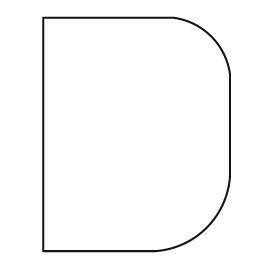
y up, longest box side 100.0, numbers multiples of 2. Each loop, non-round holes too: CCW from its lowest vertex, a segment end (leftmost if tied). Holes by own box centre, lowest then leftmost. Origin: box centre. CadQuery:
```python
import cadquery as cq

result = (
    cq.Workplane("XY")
    .moveTo(-40.0, -50.0)
    .lineTo(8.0, -50.0)
    .threePointArc((30.0, -40.0), (40.0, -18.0))
    .lineTo(40.0, 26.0)
    .threePointArc((32.0, 42.0), (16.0, 50.0))
    .lineTo(-40.0, 50.0)
    .close()
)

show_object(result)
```